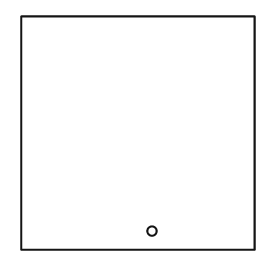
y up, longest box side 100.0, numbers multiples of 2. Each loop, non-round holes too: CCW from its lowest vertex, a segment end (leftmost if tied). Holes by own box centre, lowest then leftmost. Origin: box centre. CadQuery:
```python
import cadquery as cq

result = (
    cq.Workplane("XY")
    .moveTo(-50.0, -50.0)
    .lineTo(50.0, -50.0)
    .lineTo(50.0, 50.0)
    .lineTo(-50.0, 50.0)
    .close()
    .moveTo(6.0, -42.0)
    .circle(2.0)
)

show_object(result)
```